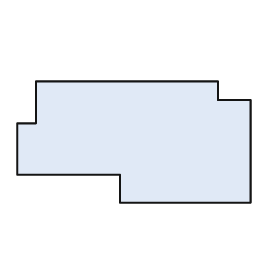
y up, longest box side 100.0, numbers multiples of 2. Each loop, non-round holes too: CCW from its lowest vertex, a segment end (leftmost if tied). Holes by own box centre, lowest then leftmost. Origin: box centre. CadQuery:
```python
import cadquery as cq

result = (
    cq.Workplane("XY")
    .moveTo(-6.0, -26.0)
    .lineTo(50.0, -26.0)
    .lineTo(50.0, 18.0)
    .lineTo(36.0, 18.0)
    .lineTo(36.0, 26.0)
    .lineTo(-42.0, 26.0)
    .lineTo(-42.0, 8.0)
    .lineTo(-50.0, 8.0)
    .lineTo(-50.0, -14.0)
    .lineTo(-6.0, -14.0)
    .close()
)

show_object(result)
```